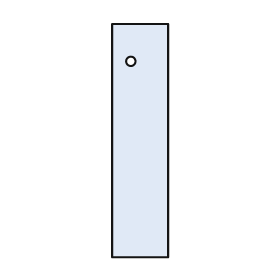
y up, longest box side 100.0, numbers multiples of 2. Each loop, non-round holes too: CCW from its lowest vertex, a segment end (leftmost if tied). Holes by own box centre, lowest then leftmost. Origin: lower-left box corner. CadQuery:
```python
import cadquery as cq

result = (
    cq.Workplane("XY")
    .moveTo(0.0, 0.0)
    .lineTo(24.0, 0.0)
    .lineTo(24.0, 100.0)
    .lineTo(0.0, 100.0)
    .close()
    .moveTo(8.0, 84.0)
    .circle(2.0)
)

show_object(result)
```